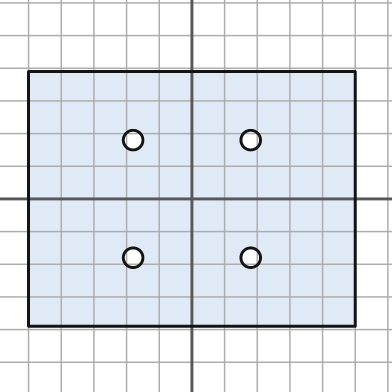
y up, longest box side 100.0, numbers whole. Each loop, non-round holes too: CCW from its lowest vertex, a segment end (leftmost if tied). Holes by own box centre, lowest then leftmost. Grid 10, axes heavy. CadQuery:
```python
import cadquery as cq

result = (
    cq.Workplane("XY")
    .moveTo(-50.0, -39.0)
    .lineTo(50.0, -39.0)
    .lineTo(50.0, 39.0)
    .lineTo(-50.0, 39.0)
    .close()
    .moveTo(-18.0, -18.0)
    .circle(3.0)
    .moveTo(18.0, -18.0)
    .circle(3.0)
    .moveTo(-18.0, 18.0)
    .circle(3.0)
    .moveTo(18.0, 18.0)
    .circle(3.0)
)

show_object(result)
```